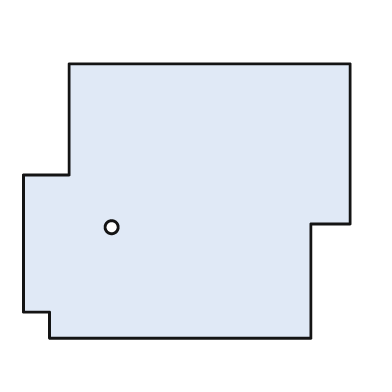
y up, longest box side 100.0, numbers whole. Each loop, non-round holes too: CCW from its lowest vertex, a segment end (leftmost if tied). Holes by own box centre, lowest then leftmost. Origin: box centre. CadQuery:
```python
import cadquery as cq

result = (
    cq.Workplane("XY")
    .moveTo(-42.0, -42.0)
    .lineTo(38.0, -42.0)
    .lineTo(38.0, -7.0)
    .lineTo(50.0, -7.0)
    .lineTo(50.0, 42.0)
    .lineTo(-36.0, 42.0)
    .lineTo(-36.0, 8.0)
    .lineTo(-50.0, 8.0)
    .lineTo(-50.0, -34.0)
    .lineTo(-42.0, -34.0)
    .close()
    .moveTo(-23.0, -8.0)
    .circle(2.0)
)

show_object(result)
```